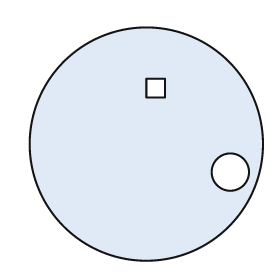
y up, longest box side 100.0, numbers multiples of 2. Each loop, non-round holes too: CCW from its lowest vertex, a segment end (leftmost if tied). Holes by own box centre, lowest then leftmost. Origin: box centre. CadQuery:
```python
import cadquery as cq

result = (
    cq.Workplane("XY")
    .moveTo(0.0, 0.0)
    .circle(50.0)
    .moveTo(36.0, -12.0)
    .circle(8.0)
    .moveTo(0.0, 20.0)
    .lineTo(8.0, 20.0)
    .lineTo(8.0, 28.0)
    .lineTo(0.0, 28.0)
    .close()
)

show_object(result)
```